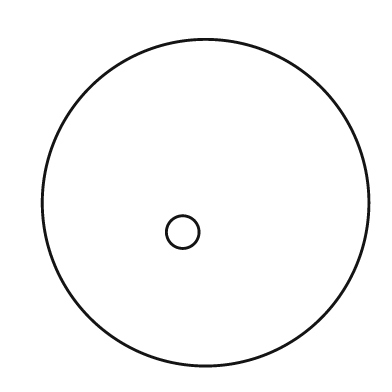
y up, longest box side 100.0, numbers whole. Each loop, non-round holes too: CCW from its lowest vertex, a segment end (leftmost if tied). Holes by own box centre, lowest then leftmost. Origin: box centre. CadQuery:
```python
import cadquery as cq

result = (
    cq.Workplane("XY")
    .moveTo(0.0, 0.0)
    .circle(50.0)
    .moveTo(-7.0, -9.0)
    .circle(5.0)
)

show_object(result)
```